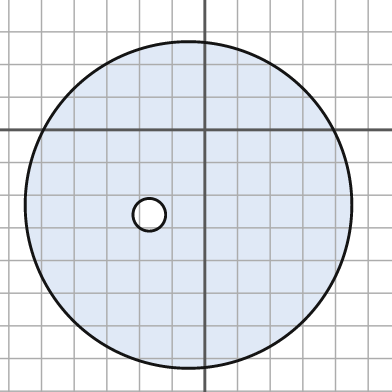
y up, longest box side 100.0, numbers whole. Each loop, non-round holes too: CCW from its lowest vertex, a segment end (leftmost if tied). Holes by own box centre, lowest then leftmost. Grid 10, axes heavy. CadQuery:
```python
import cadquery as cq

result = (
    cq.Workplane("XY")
    .moveTo(-5.0, -23.0)
    .circle(50.0)
    .moveTo(-17.0, -26.0)
    .circle(5.0)
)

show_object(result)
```